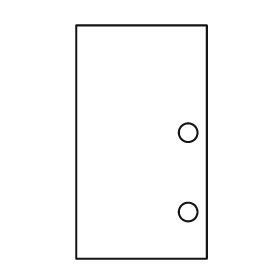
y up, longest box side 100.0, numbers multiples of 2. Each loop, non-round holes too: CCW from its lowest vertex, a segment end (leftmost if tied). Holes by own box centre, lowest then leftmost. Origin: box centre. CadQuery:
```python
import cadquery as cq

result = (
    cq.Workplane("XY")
    .moveTo(-28.0, -50.0)
    .lineTo(28.0, -50.0)
    .lineTo(28.0, 50.0)
    .lineTo(-28.0, 50.0)
    .close()
    .moveTo(20.0, -30.0)
    .circle(4.0)
    .moveTo(20.0, 4.0)
    .circle(4.0)
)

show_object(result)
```